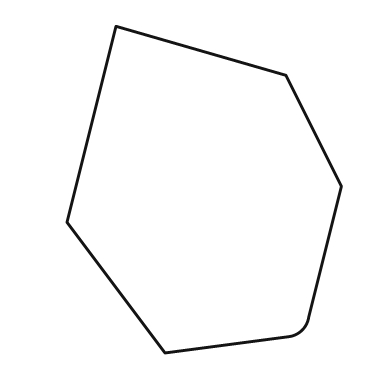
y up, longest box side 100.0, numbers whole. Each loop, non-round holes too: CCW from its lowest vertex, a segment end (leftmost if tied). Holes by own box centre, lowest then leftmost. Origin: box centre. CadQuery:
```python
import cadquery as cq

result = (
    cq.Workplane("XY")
    .moveTo(-12.0, -50.0)
    .lineTo(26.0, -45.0)
    .threePointArc((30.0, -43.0), (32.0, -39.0))
    .lineTo(42.0, 1.0)
    .lineTo(25.0, 35.0)
    .lineTo(-27.0, 50.0)
    .lineTo(-42.0, -10.0)
    .close()
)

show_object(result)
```